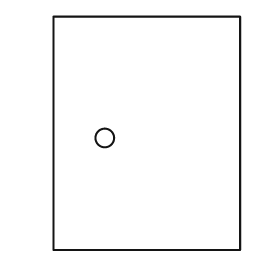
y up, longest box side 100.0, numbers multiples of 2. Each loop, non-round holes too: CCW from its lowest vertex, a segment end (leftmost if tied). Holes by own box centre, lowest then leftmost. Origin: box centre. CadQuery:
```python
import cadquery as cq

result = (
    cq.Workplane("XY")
    .moveTo(-40.0, -50.0)
    .lineTo(40.0, -50.0)
    .lineTo(40.0, 50.0)
    .lineTo(-40.0, 50.0)
    .close()
    .moveTo(-18.0, -2.0)
    .circle(4.0)
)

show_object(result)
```